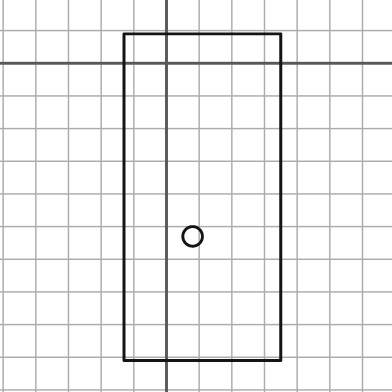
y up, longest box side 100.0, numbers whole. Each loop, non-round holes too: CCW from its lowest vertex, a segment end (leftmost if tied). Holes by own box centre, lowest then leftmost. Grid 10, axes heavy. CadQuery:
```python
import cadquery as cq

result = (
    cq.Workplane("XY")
    .moveTo(-13.0, -91.0)
    .lineTo(35.0, -91.0)
    .lineTo(35.0, 9.0)
    .lineTo(-13.0, 9.0)
    .close()
    .moveTo(8.0, -53.0)
    .circle(3.0)
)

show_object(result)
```